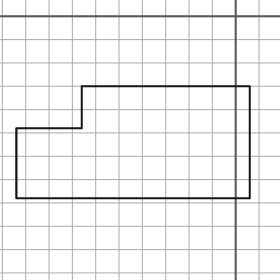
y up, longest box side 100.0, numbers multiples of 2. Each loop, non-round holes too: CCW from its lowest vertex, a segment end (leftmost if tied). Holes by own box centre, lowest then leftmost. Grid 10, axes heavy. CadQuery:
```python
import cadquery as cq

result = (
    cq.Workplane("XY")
    .moveTo(-94.0, -78.0)
    .lineTo(6.0, -78.0)
    .lineTo(6.0, -30.0)
    .lineTo(-66.0, -30.0)
    .lineTo(-66.0, -48.0)
    .lineTo(-94.0, -48.0)
    .close()
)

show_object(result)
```